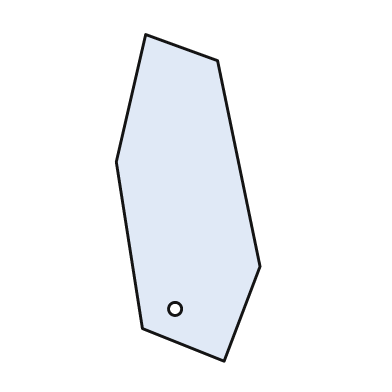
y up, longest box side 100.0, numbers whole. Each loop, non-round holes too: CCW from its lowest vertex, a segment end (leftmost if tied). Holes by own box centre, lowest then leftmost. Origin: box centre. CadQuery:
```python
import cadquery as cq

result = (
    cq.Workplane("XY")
    .moveTo(11.0, -50.0)
    .lineTo(22.0, -21.0)
    .lineTo(9.0, 42.0)
    .lineTo(-13.0, 50.0)
    .lineTo(-22.0, 11.0)
    .lineTo(-14.0, -40.0)
    .close()
    .moveTo(-4.0, -34.0)
    .circle(2.0)
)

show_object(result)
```